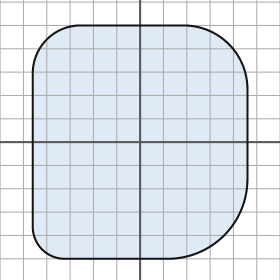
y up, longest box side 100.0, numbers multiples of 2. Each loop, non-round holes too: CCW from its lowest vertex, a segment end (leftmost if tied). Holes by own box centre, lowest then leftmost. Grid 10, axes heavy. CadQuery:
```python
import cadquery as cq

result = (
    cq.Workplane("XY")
    .moveTo(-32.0, -50.0)
    .lineTo(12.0, -50.0)
    .threePointArc((36.0, -40.0), (46.0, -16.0))
    .lineTo(46.0, 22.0)
    .threePointArc((38.0, 42.0), (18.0, 50.0))
    .lineTo(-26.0, 50.0)
    .threePointArc((-40.0, 44.0), (-46.0, 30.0))
    .lineTo(-46.0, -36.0)
    .threePointArc((-42.0, -46.0), (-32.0, -50.0))
    .close()
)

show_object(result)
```